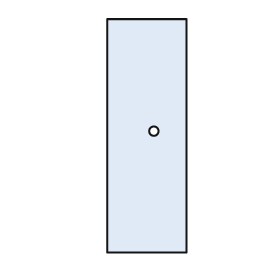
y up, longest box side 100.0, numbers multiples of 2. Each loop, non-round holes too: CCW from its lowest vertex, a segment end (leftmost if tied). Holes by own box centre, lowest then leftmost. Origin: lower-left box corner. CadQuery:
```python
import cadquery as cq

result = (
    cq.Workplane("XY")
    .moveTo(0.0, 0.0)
    .lineTo(34.0, 0.0)
    .lineTo(34.0, 100.0)
    .lineTo(0.0, 100.0)
    .close()
    .moveTo(20.0, 52.0)
    .circle(2.0)
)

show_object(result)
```